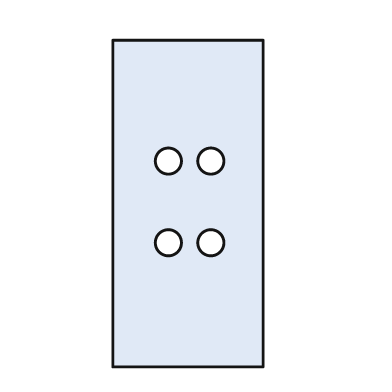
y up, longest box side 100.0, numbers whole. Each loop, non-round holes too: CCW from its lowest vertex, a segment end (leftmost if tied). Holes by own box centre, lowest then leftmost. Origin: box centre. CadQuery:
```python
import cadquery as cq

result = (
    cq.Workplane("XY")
    .moveTo(-23.0, -50.0)
    .lineTo(23.0, -50.0)
    .lineTo(23.0, 50.0)
    .lineTo(-23.0, 50.0)
    .close()
    .moveTo(-6.0, -12.0)
    .circle(4.0)
    .moveTo(7.0, -12.0)
    .circle(4.0)
    .moveTo(-6.0, 13.0)
    .circle(4.0)
    .moveTo(7.0, 13.0)
    .circle(4.0)
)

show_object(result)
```